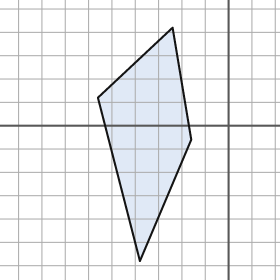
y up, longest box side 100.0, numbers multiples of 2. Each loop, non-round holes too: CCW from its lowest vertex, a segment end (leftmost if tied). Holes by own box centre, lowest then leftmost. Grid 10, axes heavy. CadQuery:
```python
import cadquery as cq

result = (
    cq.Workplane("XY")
    .moveTo(-38.0, -58.0)
    .lineTo(-16.0, -6.0)
    .lineTo(-24.0, 42.0)
    .lineTo(-56.0, 12.0)
    .close()
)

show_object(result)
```